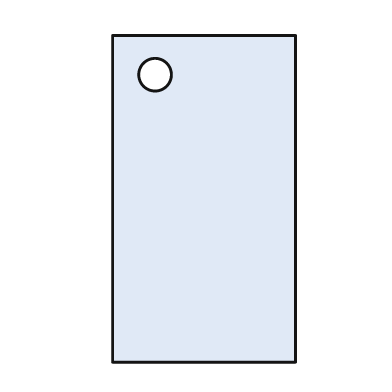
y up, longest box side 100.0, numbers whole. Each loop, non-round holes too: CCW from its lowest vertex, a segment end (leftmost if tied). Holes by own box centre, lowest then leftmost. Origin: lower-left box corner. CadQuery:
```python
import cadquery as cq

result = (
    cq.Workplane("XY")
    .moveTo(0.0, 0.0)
    .lineTo(56.0, 0.0)
    .lineTo(56.0, 100.0)
    .lineTo(0.0, 100.0)
    .close()
    .moveTo(13.0, 88.0)
    .circle(5.0)
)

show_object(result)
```